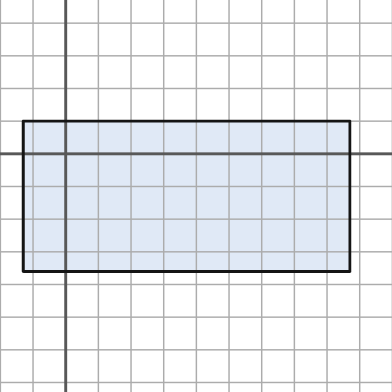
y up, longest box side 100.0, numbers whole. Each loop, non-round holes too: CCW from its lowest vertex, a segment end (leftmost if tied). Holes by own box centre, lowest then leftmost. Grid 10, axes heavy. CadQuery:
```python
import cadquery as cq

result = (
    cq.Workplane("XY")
    .moveTo(-13.0, -36.0)
    .lineTo(87.0, -36.0)
    .lineTo(87.0, 10.0)
    .lineTo(-13.0, 10.0)
    .close()
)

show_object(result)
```